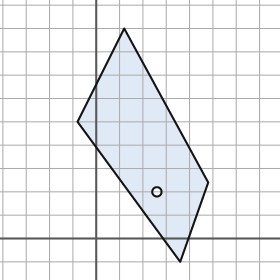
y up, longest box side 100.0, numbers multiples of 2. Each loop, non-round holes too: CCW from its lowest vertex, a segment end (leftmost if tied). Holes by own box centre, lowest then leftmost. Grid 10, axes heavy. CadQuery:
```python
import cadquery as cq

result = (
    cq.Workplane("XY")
    .moveTo(36.0, -10.0)
    .lineTo(48.0, 24.0)
    .lineTo(12.0, 90.0)
    .lineTo(-8.0, 50.0)
    .close()
    .moveTo(26.0, 20.0)
    .circle(2.0)
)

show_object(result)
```